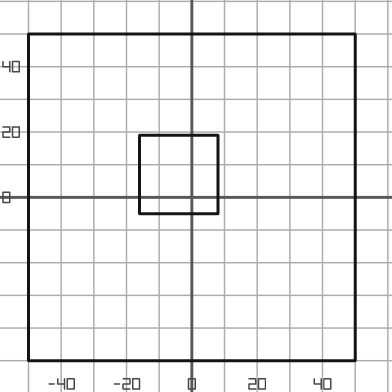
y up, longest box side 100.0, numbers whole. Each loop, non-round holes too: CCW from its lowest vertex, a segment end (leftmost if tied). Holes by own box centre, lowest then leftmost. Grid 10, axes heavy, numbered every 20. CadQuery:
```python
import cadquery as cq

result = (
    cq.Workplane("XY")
    .moveTo(-50.0, -50.0)
    .lineTo(50.0, -50.0)
    .lineTo(50.0, 50.0)
    .lineTo(-50.0, 50.0)
    .close()
    .moveTo(-16.0, -5.0)
    .lineTo(8.0, -5.0)
    .lineTo(8.0, 19.0)
    .lineTo(-16.0, 19.0)
    .close()
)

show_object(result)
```